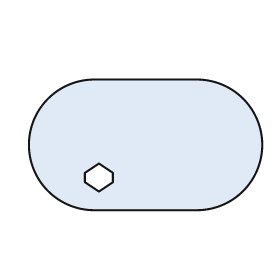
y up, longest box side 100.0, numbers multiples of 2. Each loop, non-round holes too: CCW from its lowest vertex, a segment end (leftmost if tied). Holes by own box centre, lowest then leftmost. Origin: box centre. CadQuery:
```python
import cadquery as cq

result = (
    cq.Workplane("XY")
    .moveTo(-22.0, -28.0)
    .lineTo(22.0, -28.0)
    .threePointArc((50.0, 0.0), (22.0, 28.0))
    .lineTo(-22.0, 28.0)
    .threePointArc((-50.0, 0.0), (-22.0, -28.0))
    .close()
    .moveTo(-20.0, -20.0)
    .lineTo(-14.0, -16.0)
    .lineTo(-14.0, -12.0)
    .lineTo(-20.0, -8.0)
    .lineTo(-26.0, -12.0)
    .lineTo(-26.0, -16.0)
    .close()
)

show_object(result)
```